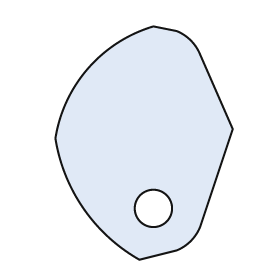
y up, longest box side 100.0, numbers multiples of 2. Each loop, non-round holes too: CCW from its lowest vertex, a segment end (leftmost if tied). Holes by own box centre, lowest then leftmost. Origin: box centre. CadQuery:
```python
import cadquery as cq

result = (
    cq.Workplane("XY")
    .moveTo(-2.0, -50.0)
    .lineTo(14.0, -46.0)
    .threePointArc((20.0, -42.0), (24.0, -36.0))
    .lineTo(38.0, 6.0)
    .lineTo(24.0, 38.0)
    .threePointArc((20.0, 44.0), (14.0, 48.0))
    .lineTo(4.0, 50.0)
    .threePointArc((-24.0, 32.0), (-38.0, 2.0))
    .threePointArc((-26.0, -28.0), (-2.0, -50.0))
    .close()
    .moveTo(4.0, -28.0)
    .circle(8.0)
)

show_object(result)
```